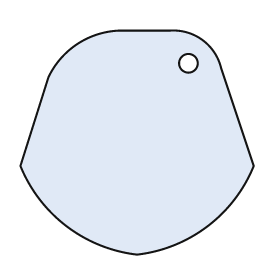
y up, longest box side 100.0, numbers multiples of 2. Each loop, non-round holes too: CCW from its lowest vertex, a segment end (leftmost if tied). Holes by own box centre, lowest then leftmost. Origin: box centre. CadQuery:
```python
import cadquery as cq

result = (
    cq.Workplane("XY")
    .moveTo(0.0, -48.0)
    .threePointArc((30.0, -36.0), (50.0, -10.0))
    .lineTo(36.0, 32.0)
    .threePointArc((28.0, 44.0), (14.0, 48.0))
    .lineTo(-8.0, 48.0)
    .threePointArc((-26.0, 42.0), (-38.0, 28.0))
    .lineTo(-50.0, -10.0)
    .threePointArc((-30.0, -36.0), (0.0, -48.0))
    .close()
    .moveTo(22.0, 34.0)
    .circle(4.0)
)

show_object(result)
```